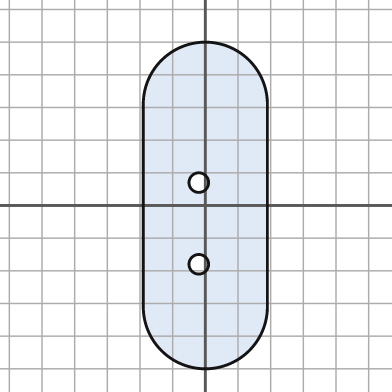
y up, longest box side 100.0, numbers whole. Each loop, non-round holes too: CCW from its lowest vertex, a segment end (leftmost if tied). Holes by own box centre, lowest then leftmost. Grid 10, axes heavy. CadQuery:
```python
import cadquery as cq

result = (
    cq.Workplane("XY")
    .moveTo(-19.0, -31.0)
    .threePointArc((0.0, -50.0), (19.0, -31.0))
    .lineTo(19.0, 31.0)
    .threePointArc((0.0, 50.0), (-19.0, 31.0))
    .close()
    .moveTo(-2.0, -18.0)
    .circle(3.0)
    .moveTo(-2.0, 7.0)
    .circle(3.0)
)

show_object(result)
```